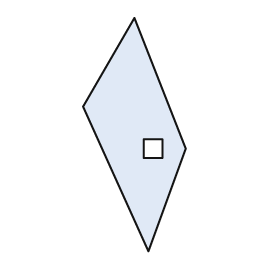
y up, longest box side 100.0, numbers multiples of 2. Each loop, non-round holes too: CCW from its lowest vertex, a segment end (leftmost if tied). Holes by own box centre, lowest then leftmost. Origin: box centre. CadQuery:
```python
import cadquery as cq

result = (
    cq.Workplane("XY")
    .moveTo(6.0, -50.0)
    .lineTo(22.0, -6.0)
    .lineTo(0.0, 50.0)
    .lineTo(-22.0, 12.0)
    .close()
    .moveTo(4.0, -10.0)
    .lineTo(12.0, -10.0)
    .lineTo(12.0, -2.0)
    .lineTo(4.0, -2.0)
    .close()
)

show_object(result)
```